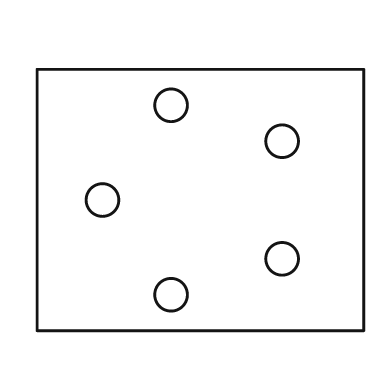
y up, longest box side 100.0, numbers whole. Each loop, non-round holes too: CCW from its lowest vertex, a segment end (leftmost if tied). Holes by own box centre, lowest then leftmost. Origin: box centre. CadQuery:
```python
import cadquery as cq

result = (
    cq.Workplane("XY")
    .moveTo(-50.0, -40.0)
    .lineTo(50.0, -40.0)
    .lineTo(50.0, 40.0)
    .lineTo(-50.0, 40.0)
    .close()
    .moveTo(-9.0, -29.0)
    .circle(5.0)
    .moveTo(25.0, -18.0)
    .circle(5.0)
    .moveTo(-30.0, 0.0)
    .circle(5.0)
    .moveTo(25.0, 18.0)
    .circle(5.0)
    .moveTo(-9.0, 29.0)
    .circle(5.0)
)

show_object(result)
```